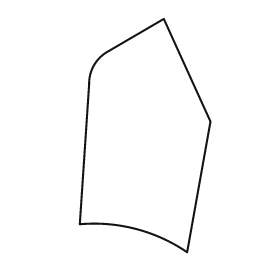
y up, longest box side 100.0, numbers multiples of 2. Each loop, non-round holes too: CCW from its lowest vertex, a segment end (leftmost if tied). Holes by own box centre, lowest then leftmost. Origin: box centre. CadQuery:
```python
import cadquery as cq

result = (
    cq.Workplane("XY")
    .moveTo(18.0, -50.0)
    .lineTo(28.0, 6.0)
    .lineTo(8.0, 50.0)
    .lineTo(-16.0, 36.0)
    .threePointArc((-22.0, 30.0), (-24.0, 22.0))
    .lineTo(-28.0, -38.0)
    .threePointArc((-4.0, -40.0), (18.0, -50.0))
    .close()
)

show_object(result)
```